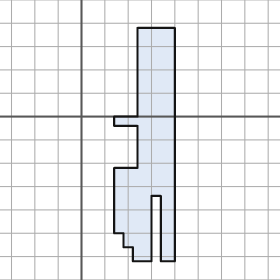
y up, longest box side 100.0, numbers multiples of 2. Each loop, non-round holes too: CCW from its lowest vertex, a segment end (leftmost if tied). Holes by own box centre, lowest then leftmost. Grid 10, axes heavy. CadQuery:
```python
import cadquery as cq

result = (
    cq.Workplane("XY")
    .moveTo(22.0, -62.0)
    .lineTo(30.0, -62.0)
    .lineTo(30.0, -34.0)
    .lineTo(34.0, -34.0)
    .lineTo(34.0, -62.0)
    .lineTo(40.0, -62.0)
    .lineTo(40.0, 38.0)
    .lineTo(24.0, 38.0)
    .lineTo(24.0, 0.0)
    .lineTo(14.0, 0.0)
    .lineTo(14.0, -4.0)
    .lineTo(24.0, -4.0)
    .lineTo(24.0, -22.0)
    .lineTo(14.0, -22.0)
    .lineTo(14.0, -50.0)
    .lineTo(18.0, -50.0)
    .lineTo(18.0, -56.0)
    .lineTo(22.0, -56.0)
    .close()
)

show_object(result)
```